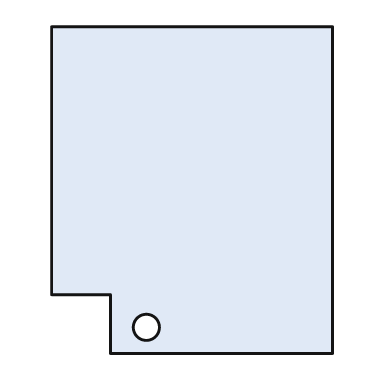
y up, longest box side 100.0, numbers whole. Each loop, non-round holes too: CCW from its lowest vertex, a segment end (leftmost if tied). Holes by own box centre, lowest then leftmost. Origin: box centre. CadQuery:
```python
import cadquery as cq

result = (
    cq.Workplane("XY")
    .moveTo(-25.0, -50.0)
    .lineTo(43.0, -50.0)
    .lineTo(43.0, 50.0)
    .lineTo(-43.0, 50.0)
    .lineTo(-43.0, -32.0)
    .lineTo(-25.0, -32.0)
    .close()
    .moveTo(-14.0, -42.0)
    .circle(4.0)
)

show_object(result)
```